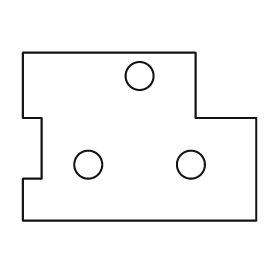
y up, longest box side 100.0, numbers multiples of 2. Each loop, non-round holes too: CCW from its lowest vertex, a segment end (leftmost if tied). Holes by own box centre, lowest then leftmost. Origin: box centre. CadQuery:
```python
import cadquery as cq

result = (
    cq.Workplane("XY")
    .moveTo(-50.0, -36.0)
    .lineTo(50.0, -36.0)
    .lineTo(50.0, 8.0)
    .lineTo(24.0, 8.0)
    .lineTo(24.0, 36.0)
    .lineTo(-50.0, 36.0)
    .lineTo(-50.0, 8.0)
    .lineTo(-42.0, 8.0)
    .lineTo(-42.0, -18.0)
    .lineTo(-50.0, -18.0)
    .close()
    .moveTo(-22.0, -12.0)
    .circle(6.0)
    .moveTo(22.0, -12.0)
    .circle(6.0)
    .moveTo(0.0, 26.0)
    .circle(6.0)
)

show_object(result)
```